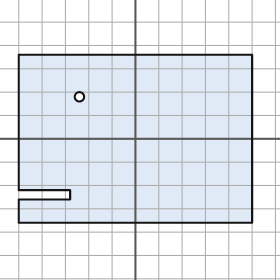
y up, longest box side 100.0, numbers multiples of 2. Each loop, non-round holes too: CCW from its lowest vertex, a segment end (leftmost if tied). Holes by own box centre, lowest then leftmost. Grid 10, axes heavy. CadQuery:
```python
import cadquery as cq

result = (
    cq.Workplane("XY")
    .moveTo(-50.0, -36.0)
    .lineTo(50.0, -36.0)
    .lineTo(50.0, 36.0)
    .lineTo(-50.0, 36.0)
    .lineTo(-50.0, -22.0)
    .lineTo(-28.0, -22.0)
    .lineTo(-28.0, -26.0)
    .lineTo(-50.0, -26.0)
    .close()
    .moveTo(-24.0, 18.0)
    .circle(2.0)
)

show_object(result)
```